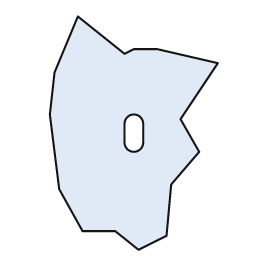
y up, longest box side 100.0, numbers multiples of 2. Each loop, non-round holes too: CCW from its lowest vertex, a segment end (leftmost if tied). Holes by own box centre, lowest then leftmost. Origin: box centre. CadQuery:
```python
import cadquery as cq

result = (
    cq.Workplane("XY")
    .moveTo(2.0, -50.0)
    .lineTo(14.0, -44.0)
    .lineTo(16.0, -22.0)
    .lineTo(28.0, -8.0)
    .lineTo(20.0, 6.0)
    .lineTo(36.0, 30.0)
    .lineTo(10.0, 36.0)
    .lineTo(0.0, 36.0)
    .lineTo(-4.0, 34.0)
    .lineTo(-24.0, 50.0)
    .lineTo(-34.0, 26.0)
    .lineTo(-36.0, 8.0)
    .lineTo(-32.0, -24.0)
    .lineTo(-22.0, -42.0)
    .lineTo(-8.0, -42.0)
    .close()
    .moveTo(-4.0, -4.0)
    .threePointArc((0.0, -8.0), (4.0, -4.0))
    .lineTo(4.0, 4.0)
    .threePointArc((0.0, 8.0), (-4.0, 4.0))
    .close()
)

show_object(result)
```